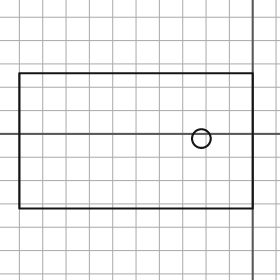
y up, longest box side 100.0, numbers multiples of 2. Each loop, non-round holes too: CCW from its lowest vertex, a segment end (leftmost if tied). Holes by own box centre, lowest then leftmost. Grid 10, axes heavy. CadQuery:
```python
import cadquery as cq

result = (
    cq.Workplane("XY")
    .moveTo(-100.0, -32.0)
    .lineTo(0.0, -32.0)
    .lineTo(0.0, 26.0)
    .lineTo(-100.0, 26.0)
    .close()
    .moveTo(-22.0, -2.0)
    .circle(4.0)
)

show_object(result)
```